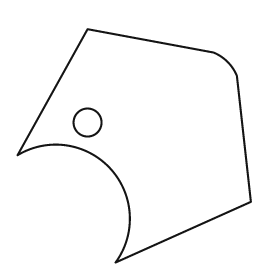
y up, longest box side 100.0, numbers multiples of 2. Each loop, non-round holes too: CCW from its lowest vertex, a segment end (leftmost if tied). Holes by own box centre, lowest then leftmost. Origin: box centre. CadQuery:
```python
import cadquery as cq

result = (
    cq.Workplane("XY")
    .moveTo(-8.0, -50.0)
    .lineTo(50.0, -24.0)
    .lineTo(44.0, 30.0)
    .threePointArc((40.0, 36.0), (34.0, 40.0))
    .lineTo(-20.0, 50.0)
    .lineTo(-50.0, -4.0)
    .threePointArc((-10.0, -10.0), (-8.0, -50.0))
    .close()
    .moveTo(-20.0, 10.0)
    .circle(6.0)
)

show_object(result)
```